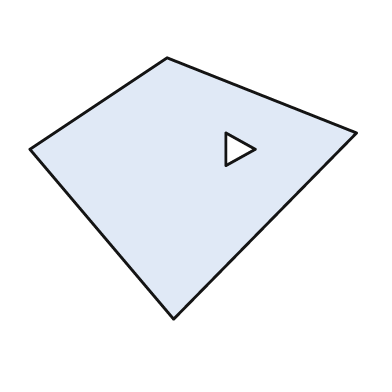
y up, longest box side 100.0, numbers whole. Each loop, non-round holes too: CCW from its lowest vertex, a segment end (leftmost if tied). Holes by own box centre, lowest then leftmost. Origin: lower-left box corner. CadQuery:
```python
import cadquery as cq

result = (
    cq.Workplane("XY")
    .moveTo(44.0, 0.0)
    .lineTo(100.0, 57.0)
    .lineTo(42.0, 80.0)
    .lineTo(0.0, 52.0)
    .close()
    .moveTo(60.0, 47.0)
    .lineTo(69.0, 52.0)
    .lineTo(60.0, 57.0)
    .close()
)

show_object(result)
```